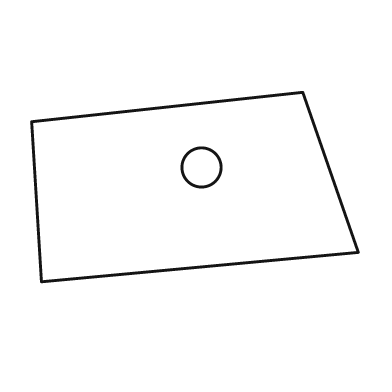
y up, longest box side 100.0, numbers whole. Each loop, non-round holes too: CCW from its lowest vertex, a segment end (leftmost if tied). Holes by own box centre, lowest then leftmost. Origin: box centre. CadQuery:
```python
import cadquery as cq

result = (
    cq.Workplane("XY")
    .moveTo(-47.0, -29.0)
    .lineTo(50.0, -20.0)
    .lineTo(33.0, 29.0)
    .lineTo(-50.0, 20.0)
    .close()
    .moveTo(2.0, 6.0)
    .circle(6.0)
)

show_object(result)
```